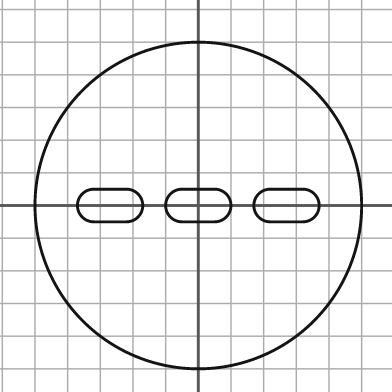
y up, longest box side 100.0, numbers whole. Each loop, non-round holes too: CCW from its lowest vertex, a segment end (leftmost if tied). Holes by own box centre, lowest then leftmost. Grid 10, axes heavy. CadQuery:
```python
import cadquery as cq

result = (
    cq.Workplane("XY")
    .moveTo(0.0, 0.0)
    .circle(50.0)
    .moveTo(-32.0, -5.0)
    .lineTo(-22.0, -5.0)
    .threePointArc((-17.0, 0.0), (-22.0, 5.0))
    .lineTo(-32.0, 5.0)
    .threePointArc((-37.0, 0.0), (-32.0, -5.0))
    .close()
    .moveTo(-5.0, -5.0)
    .lineTo(5.0, -5.0)
    .threePointArc((10.0, 0.0), (5.0, 5.0))
    .lineTo(-5.0, 5.0)
    .threePointArc((-10.0, 0.0), (-5.0, -5.0))
    .close()
    .moveTo(22.0, -5.0)
    .lineTo(32.0, -5.0)
    .threePointArc((37.0, 0.0), (32.0, 5.0))
    .lineTo(22.0, 5.0)
    .threePointArc((17.0, 0.0), (22.0, -5.0))
    .close()
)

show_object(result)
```